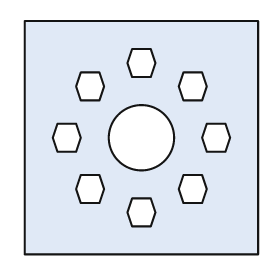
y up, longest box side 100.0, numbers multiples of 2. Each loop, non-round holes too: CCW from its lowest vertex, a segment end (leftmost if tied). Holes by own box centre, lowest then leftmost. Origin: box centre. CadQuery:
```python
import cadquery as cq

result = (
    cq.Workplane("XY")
    .moveTo(-50.0, -50.0)
    .lineTo(50.0, -50.0)
    .lineTo(50.0, 50.0)
    .lineTo(-50.0, 50.0)
    .close()
    .moveTo(-4.0, -38.0)
    .lineTo(4.0, -38.0)
    .lineTo(6.0, -32.0)
    .lineTo(4.0, -26.0)
    .lineTo(-4.0, -26.0)
    .lineTo(-6.0, -32.0)
    .close()
    .moveTo(-26.0, -28.0)
    .lineTo(-18.0, -28.0)
    .lineTo(-16.0, -22.0)
    .lineTo(-18.0, -16.0)
    .lineTo(-26.0, -16.0)
    .lineTo(-28.0, -22.0)
    .close()
    .moveTo(18.0, -28.0)
    .lineTo(26.0, -28.0)
    .lineTo(28.0, -22.0)
    .lineTo(26.0, -16.0)
    .lineTo(18.0, -16.0)
    .lineTo(16.0, -22.0)
    .close()
    .moveTo(-36.0, -6.0)
    .lineTo(-28.0, -6.0)
    .lineTo(-26.0, 0.0)
    .lineTo(-28.0, 6.0)
    .lineTo(-36.0, 6.0)
    .lineTo(-38.0, 0.0)
    .close()
    .moveTo(0.0, 0.0)
    .circle(14.0)
    .moveTo(28.0, -6.0)
    .lineTo(36.0, -6.0)
    .lineTo(38.0, 0.0)
    .lineTo(36.0, 6.0)
    .lineTo(28.0, 6.0)
    .lineTo(26.0, 0.0)
    .close()
    .moveTo(-26.0, 16.0)
    .lineTo(-18.0, 16.0)
    .lineTo(-16.0, 22.0)
    .lineTo(-18.0, 28.0)
    .lineTo(-26.0, 28.0)
    .lineTo(-28.0, 22.0)
    .close()
    .moveTo(18.0, 16.0)
    .lineTo(26.0, 16.0)
    .lineTo(28.0, 22.0)
    .lineTo(26.0, 28.0)
    .lineTo(18.0, 28.0)
    .lineTo(16.0, 22.0)
    .close()
    .moveTo(-4.0, 26.0)
    .lineTo(4.0, 26.0)
    .lineTo(6.0, 32.0)
    .lineTo(4.0, 38.0)
    .lineTo(-4.0, 38.0)
    .lineTo(-6.0, 32.0)
    .close()
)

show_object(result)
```